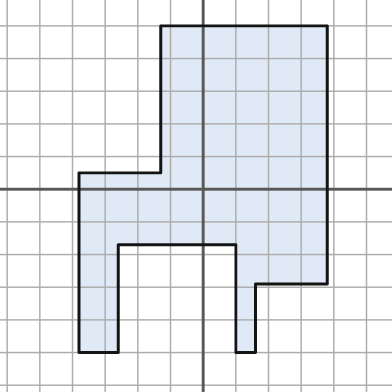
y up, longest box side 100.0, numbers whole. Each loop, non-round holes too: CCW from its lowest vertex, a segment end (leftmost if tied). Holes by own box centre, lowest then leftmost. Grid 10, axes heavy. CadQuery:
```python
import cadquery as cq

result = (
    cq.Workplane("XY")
    .moveTo(-38.0, -50.0)
    .lineTo(-26.0, -50.0)
    .lineTo(-26.0, -17.0)
    .lineTo(10.0, -17.0)
    .lineTo(10.0, -50.0)
    .lineTo(16.0, -50.0)
    .lineTo(16.0, -29.0)
    .lineTo(38.0, -29.0)
    .lineTo(38.0, 50.0)
    .lineTo(-13.0, 50.0)
    .lineTo(-13.0, 5.0)
    .lineTo(-38.0, 5.0)
    .close()
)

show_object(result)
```